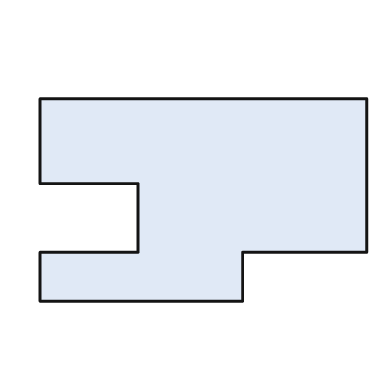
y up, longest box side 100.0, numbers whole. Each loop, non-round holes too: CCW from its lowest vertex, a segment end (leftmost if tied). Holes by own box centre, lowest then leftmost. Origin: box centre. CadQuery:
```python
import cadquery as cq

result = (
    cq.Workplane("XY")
    .moveTo(-50.0, -31.0)
    .lineTo(12.0, -31.0)
    .lineTo(12.0, -16.0)
    .lineTo(50.0, -16.0)
    .lineTo(50.0, 31.0)
    .lineTo(-50.0, 31.0)
    .lineTo(-50.0, 5.0)
    .lineTo(-20.0, 5.0)
    .lineTo(-20.0, -16.0)
    .lineTo(-50.0, -16.0)
    .close()
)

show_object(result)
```